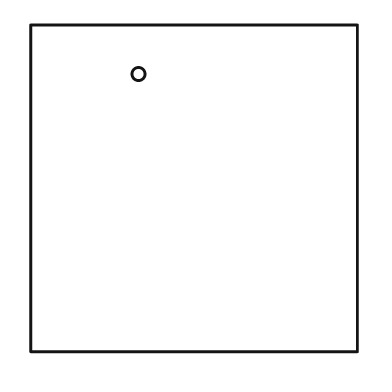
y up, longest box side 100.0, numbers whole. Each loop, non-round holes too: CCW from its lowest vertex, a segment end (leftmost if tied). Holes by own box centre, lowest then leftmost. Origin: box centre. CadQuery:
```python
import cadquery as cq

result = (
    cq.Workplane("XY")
    .moveTo(-50.0, -50.0)
    .lineTo(50.0, -50.0)
    .lineTo(50.0, 50.0)
    .lineTo(-50.0, 50.0)
    .close()
    .moveTo(-17.0, 35.0)
    .circle(2.0)
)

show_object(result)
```